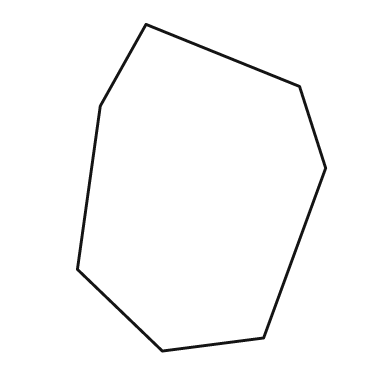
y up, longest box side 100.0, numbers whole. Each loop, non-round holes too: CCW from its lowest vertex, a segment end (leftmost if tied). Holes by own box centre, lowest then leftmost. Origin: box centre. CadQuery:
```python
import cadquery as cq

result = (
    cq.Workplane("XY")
    .moveTo(-12.0, -50.0)
    .lineTo(19.0, -46.0)
    .lineTo(38.0, 6.0)
    .lineTo(30.0, 31.0)
    .lineTo(-17.0, 50.0)
    .lineTo(-31.0, 25.0)
    .lineTo(-38.0, -25.0)
    .close()
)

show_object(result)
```